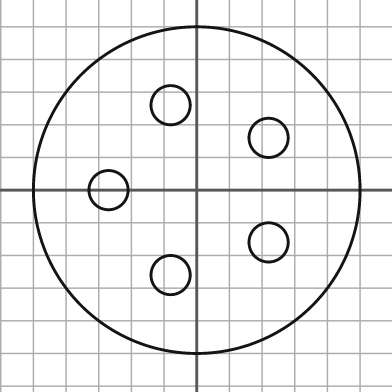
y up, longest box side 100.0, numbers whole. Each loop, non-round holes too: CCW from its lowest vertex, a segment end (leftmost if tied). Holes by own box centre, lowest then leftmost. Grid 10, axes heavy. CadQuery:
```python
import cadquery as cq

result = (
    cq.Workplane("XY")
    .moveTo(0.0, 0.0)
    .circle(50.0)
    .moveTo(-8.0, -26.0)
    .circle(6.0)
    .moveTo(22.0, -16.0)
    .circle(6.0)
    .moveTo(-27.0, 0.0)
    .circle(6.0)
    .moveTo(22.0, 16.0)
    .circle(6.0)
    .moveTo(-8.0, 26.0)
    .circle(6.0)
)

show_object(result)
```